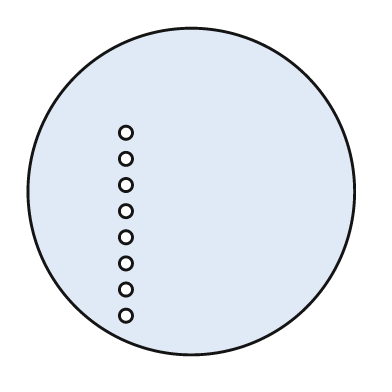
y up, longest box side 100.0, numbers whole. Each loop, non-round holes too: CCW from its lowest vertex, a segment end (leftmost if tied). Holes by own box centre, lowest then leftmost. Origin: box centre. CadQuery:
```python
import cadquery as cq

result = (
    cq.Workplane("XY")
    .moveTo(0.0, 0.0)
    .circle(50.0)
    .moveTo(-20.0, -38.0)
    .circle(2.0)
    .moveTo(-20.0, -30.0)
    .circle(2.0)
    .moveTo(-20.0, -22.0)
    .circle(2.0)
    .moveTo(-20.0, -14.0)
    .circle(2.0)
    .moveTo(-20.0, -6.0)
    .circle(2.0)
    .moveTo(-20.0, 2.0)
    .circle(2.0)
    .moveTo(-20.0, 10.0)
    .circle(2.0)
    .moveTo(-20.0, 18.0)
    .circle(2.0)
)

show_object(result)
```